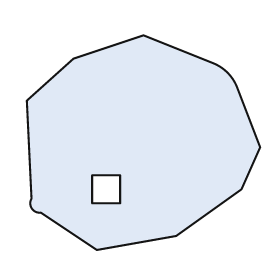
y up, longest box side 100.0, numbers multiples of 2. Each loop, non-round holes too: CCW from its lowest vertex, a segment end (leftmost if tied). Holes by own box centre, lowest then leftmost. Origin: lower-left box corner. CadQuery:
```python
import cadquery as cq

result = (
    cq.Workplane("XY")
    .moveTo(30.0, 0.0)
    .lineTo(64.0, 6.0)
    .lineTo(92.0, 26.0)
    .lineTo(100.0, 44.0)
    .lineTo(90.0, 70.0)
    .threePointArc((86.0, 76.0), (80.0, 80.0))
    .lineTo(50.0, 92.0)
    .lineTo(20.0, 82.0)
    .lineTo(0.0, 64.0)
    .lineTo(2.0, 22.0)
    .threePointArc((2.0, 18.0), (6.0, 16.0))
    .close()
    .moveTo(28.0, 20.0)
    .lineTo(40.0, 20.0)
    .lineTo(40.0, 32.0)
    .lineTo(28.0, 32.0)
    .close()
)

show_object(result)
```